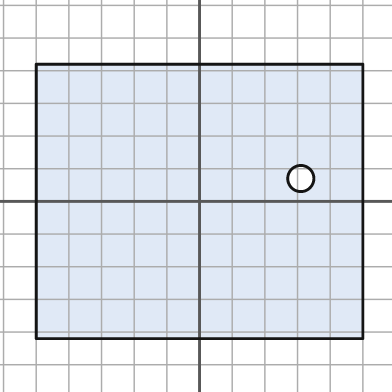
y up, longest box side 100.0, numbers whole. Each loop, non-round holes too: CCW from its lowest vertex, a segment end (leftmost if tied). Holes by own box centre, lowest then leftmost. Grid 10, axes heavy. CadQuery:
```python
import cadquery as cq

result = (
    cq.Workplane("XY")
    .moveTo(-50.0, -42.0)
    .lineTo(50.0, -42.0)
    .lineTo(50.0, 42.0)
    .lineTo(-50.0, 42.0)
    .close()
    .moveTo(31.0, 7.0)
    .circle(4.0)
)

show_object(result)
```